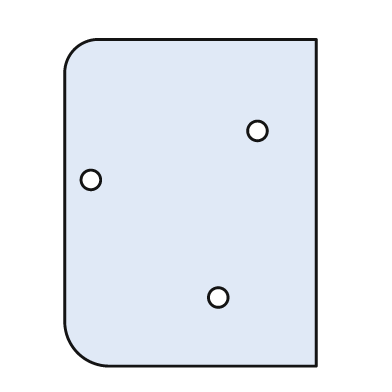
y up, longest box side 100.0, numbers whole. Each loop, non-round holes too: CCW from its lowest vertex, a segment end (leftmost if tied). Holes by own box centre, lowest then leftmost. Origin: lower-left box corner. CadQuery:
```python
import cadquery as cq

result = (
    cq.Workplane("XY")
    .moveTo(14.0, 0.0)
    .lineTo(77.0, 0.0)
    .lineTo(77.0, 100.0)
    .lineTo(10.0, 100.0)
    .threePointArc((3.0, 97.0), (0.0, 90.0))
    .lineTo(0.0, 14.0)
    .threePointArc((4.0, 4.0), (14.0, 0.0))
    .close()
    .moveTo(47.0, 21.0)
    .circle(3.0)
    .moveTo(8.0, 57.0)
    .circle(3.0)
    .moveTo(59.0, 72.0)
    .circle(3.0)
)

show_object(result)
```